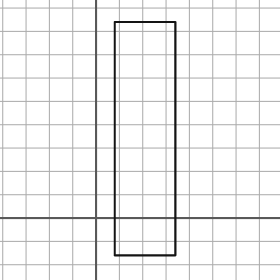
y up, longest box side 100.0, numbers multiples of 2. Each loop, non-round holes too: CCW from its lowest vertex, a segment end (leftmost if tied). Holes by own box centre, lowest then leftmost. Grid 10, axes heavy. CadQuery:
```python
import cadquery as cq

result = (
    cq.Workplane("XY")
    .moveTo(8.0, -16.0)
    .lineTo(34.0, -16.0)
    .lineTo(34.0, 84.0)
    .lineTo(8.0, 84.0)
    .close()
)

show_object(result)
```